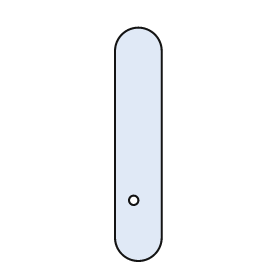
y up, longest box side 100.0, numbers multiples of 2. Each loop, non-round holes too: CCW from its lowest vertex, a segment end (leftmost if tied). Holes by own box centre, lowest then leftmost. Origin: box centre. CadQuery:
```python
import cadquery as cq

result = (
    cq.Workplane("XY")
    .moveTo(-10.0, -40.0)
    .threePointArc((0.0, -50.0), (10.0, -40.0))
    .lineTo(10.0, 40.0)
    .threePointArc((0.0, 50.0), (-10.0, 40.0))
    .close()
    .moveTo(-2.0, -24.0)
    .circle(2.0)
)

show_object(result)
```